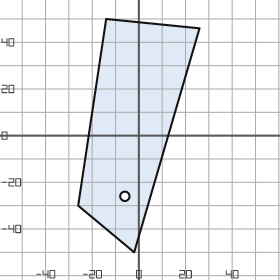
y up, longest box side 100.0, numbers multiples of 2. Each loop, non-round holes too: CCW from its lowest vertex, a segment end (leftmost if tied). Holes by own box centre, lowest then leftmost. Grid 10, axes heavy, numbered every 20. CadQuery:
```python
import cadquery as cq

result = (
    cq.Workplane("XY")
    .moveTo(-2.0, -50.0)
    .lineTo(26.0, 46.0)
    .lineTo(-14.0, 50.0)
    .lineTo(-26.0, -30.0)
    .close()
    .moveTo(-6.0, -26.0)
    .circle(2.0)
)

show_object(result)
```